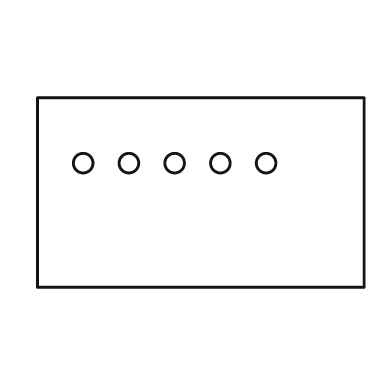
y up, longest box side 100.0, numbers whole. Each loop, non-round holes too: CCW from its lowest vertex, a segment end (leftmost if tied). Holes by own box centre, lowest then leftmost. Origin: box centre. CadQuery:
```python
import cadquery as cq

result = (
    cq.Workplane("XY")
    .moveTo(-50.0, -29.0)
    .lineTo(50.0, -29.0)
    .lineTo(50.0, 29.0)
    .lineTo(-50.0, 29.0)
    .close()
    .moveTo(-36.0, 9.0)
    .circle(3.0)
    .moveTo(-22.0, 9.0)
    .circle(3.0)
    .moveTo(-8.0, 9.0)
    .circle(3.0)
    .moveTo(6.0, 9.0)
    .circle(3.0)
    .moveTo(20.0, 9.0)
    .circle(3.0)
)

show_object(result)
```